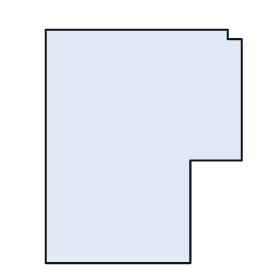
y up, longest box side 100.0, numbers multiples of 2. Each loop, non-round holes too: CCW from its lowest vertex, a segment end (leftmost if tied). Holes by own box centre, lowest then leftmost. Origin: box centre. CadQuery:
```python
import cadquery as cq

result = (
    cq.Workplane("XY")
    .moveTo(-42.0, -50.0)
    .lineTo(20.0, -50.0)
    .lineTo(20.0, -6.0)
    .lineTo(42.0, -6.0)
    .lineTo(42.0, 46.0)
    .lineTo(36.0, 46.0)
    .lineTo(36.0, 50.0)
    .lineTo(-42.0, 50.0)
    .close()
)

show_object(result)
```